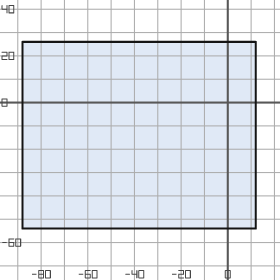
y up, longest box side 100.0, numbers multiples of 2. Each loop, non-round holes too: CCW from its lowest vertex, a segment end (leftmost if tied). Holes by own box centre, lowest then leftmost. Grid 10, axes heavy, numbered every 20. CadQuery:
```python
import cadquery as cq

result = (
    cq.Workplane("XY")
    .moveTo(-88.0, -54.0)
    .lineTo(12.0, -54.0)
    .lineTo(12.0, 26.0)
    .lineTo(-88.0, 26.0)
    .close()
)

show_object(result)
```